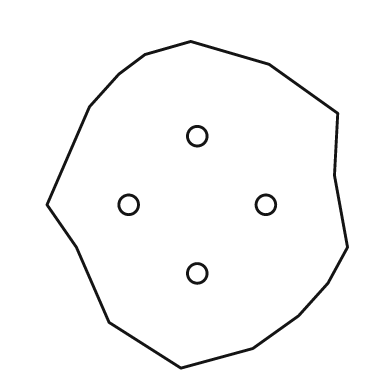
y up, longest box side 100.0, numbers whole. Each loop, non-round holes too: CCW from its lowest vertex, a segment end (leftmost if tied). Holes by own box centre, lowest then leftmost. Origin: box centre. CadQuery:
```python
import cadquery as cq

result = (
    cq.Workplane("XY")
    .moveTo(-5.0, -50.0)
    .lineTo(17.0, -44.0)
    .lineTo(31.0, -34.0)
    .lineTo(40.0, -24.0)
    .lineTo(46.0, -13.0)
    .lineTo(42.0, 9.0)
    .lineTo(43.0, 28.0)
    .lineTo(22.0, 43.0)
    .lineTo(-2.0, 50.0)
    .lineTo(-16.0, 46.0)
    .lineTo(-24.0, 40.0)
    .lineTo(-33.0, 30.0)
    .lineTo(-46.0, 0.0)
    .lineTo(-37.0, -13.0)
    .lineTo(-27.0, -36.0)
    .close()
    .moveTo(0.0, -21.0)
    .circle(3.0)
    .moveTo(-21.0, 0.0)
    .circle(3.0)
    .moveTo(21.0, 0.0)
    .circle(3.0)
    .moveTo(0.0, 21.0)
    .circle(3.0)
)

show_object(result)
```